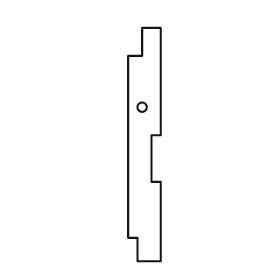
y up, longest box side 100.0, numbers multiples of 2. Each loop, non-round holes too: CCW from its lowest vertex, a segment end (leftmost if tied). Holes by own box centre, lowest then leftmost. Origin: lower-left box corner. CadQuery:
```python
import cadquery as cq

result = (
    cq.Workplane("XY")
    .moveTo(4.0, 0.0)
    .lineTo(14.0, 0.0)
    .lineTo(14.0, 34.0)
    .lineTo(10.0, 34.0)
    .lineTo(10.0, 54.0)
    .lineTo(14.0, 54.0)
    .lineTo(14.0, 100.0)
    .lineTo(6.0, 100.0)
    .lineTo(6.0, 88.0)
    .lineTo(0.0, 88.0)
    .lineTo(0.0, 10.0)
    .lineTo(4.0, 10.0)
    .close()
    .moveTo(6.0, 66.0)
    .circle(2.0)
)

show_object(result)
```